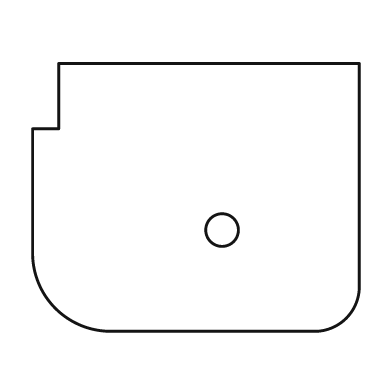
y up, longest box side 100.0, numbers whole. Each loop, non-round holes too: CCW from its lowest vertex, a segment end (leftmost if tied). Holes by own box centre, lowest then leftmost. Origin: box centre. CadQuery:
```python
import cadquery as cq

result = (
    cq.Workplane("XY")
    .moveTo(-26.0, -41.0)
    .lineTo(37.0, -41.0)
    .threePointArc((46.0, -37.0), (50.0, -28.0))
    .lineTo(50.0, 41.0)
    .lineTo(-42.0, 41.0)
    .lineTo(-42.0, 21.0)
    .lineTo(-50.0, 21.0)
    .lineTo(-50.0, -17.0)
    .threePointArc((-43.0, -34.0), (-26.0, -41.0))
    .close()
    .moveTo(8.0, -10.0)
    .circle(5.0)
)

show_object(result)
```